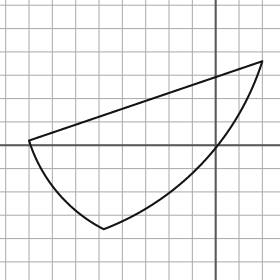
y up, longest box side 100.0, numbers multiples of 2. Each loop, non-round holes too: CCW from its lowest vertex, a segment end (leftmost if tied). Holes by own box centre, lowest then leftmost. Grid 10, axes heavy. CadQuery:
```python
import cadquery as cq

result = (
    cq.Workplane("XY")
    .moveTo(-48.0, -36.0)
    .threePointArc((-6.0, -8.0), (20.0, 36.0))
    .lineTo(-80.0, 2.0)
    .threePointArc((-68.0, -20.0), (-48.0, -36.0))
    .close()
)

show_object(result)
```